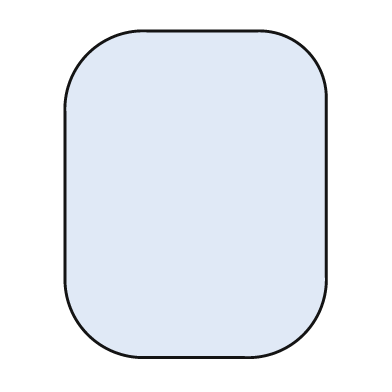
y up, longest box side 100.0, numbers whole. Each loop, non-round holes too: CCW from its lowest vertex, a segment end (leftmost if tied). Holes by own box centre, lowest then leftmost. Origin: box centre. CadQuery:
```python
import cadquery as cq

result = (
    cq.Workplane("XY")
    .moveTo(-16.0, -50.0)
    .lineTo(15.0, -50.0)
    .threePointArc((33.0, -43.0), (40.0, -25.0))
    .lineTo(40.0, 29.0)
    .threePointArc((34.0, 44.0), (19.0, 50.0))
    .lineTo(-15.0, 50.0)
    .threePointArc((-33.0, 43.0), (-40.0, 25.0))
    .lineTo(-40.0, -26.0)
    .threePointArc((-33.0, -43.0), (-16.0, -50.0))
    .close()
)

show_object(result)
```